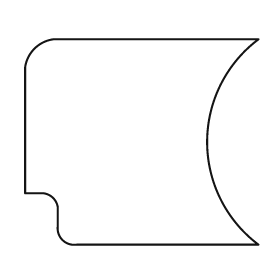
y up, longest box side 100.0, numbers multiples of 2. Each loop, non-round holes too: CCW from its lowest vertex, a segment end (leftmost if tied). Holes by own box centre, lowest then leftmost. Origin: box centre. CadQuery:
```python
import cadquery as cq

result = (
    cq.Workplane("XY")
    .moveTo(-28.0, -44.0)
    .lineTo(50.0, -44.0)
    .threePointArc((28.0, 0.0), (50.0, 44.0))
    .lineTo(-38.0, 44.0)
    .threePointArc((-46.0, 40.0), (-50.0, 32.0))
    .lineTo(-50.0, -22.0)
    .lineTo(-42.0, -22.0)
    .threePointArc((-38.0, -24.0), (-36.0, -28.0))
    .lineTo(-36.0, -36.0)
    .threePointArc((-34.0, -42.0), (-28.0, -44.0))
    .close()
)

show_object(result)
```